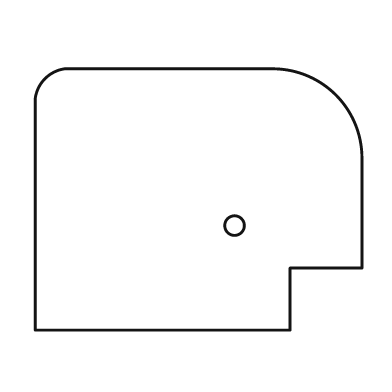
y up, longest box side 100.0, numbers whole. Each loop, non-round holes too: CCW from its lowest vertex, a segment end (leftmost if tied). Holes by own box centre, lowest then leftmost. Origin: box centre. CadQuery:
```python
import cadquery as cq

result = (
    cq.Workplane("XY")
    .moveTo(-50.0, -40.0)
    .lineTo(28.0, -40.0)
    .lineTo(28.0, -21.0)
    .lineTo(50.0, -21.0)
    .lineTo(50.0, 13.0)
    .threePointArc((42.0, 32.0), (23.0, 40.0))
    .lineTo(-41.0, 40.0)
    .threePointArc((-47.0, 37.0), (-50.0, 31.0))
    .close()
    .moveTo(11.0, -8.0)
    .circle(3.0)
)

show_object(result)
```